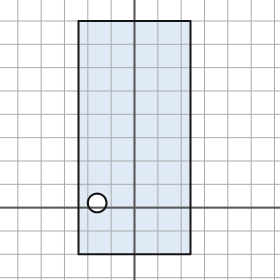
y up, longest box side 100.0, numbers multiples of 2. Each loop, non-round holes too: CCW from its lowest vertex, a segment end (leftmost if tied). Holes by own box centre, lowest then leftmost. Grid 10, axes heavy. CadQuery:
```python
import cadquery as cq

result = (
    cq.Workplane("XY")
    .moveTo(-24.0, -20.0)
    .lineTo(24.0, -20.0)
    .lineTo(24.0, 80.0)
    .lineTo(-24.0, 80.0)
    .close()
    .moveTo(-16.0, 2.0)
    .circle(4.0)
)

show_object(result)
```